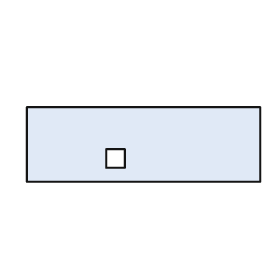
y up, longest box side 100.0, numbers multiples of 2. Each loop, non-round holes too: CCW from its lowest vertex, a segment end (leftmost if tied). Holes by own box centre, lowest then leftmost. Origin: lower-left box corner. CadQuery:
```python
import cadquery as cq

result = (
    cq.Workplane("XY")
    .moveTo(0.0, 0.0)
    .lineTo(100.0, 0.0)
    .lineTo(100.0, 32.0)
    .lineTo(0.0, 32.0)
    .close()
    .moveTo(34.0, 6.0)
    .lineTo(42.0, 6.0)
    .lineTo(42.0, 14.0)
    .lineTo(34.0, 14.0)
    .close()
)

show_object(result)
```